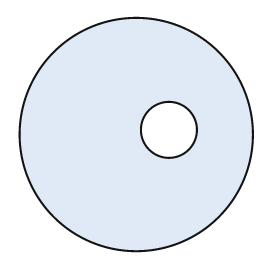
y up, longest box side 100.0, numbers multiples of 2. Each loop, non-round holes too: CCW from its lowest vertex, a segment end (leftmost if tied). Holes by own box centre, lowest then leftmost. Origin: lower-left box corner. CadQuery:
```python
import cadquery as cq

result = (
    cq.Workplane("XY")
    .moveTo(50.0, 50.0)
    .circle(50.0)
    .moveTo(64.0, 52.0)
    .circle(12.0)
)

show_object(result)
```